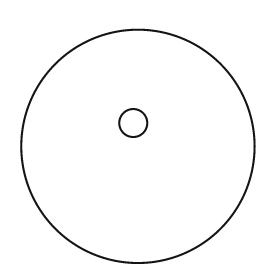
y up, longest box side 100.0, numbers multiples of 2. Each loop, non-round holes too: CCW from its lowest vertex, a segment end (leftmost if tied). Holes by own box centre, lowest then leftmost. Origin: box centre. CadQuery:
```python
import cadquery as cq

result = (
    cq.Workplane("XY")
    .moveTo(0.0, 0.0)
    .circle(50.0)
    .moveTo(-2.0, 10.0)
    .circle(6.0)
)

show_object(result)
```